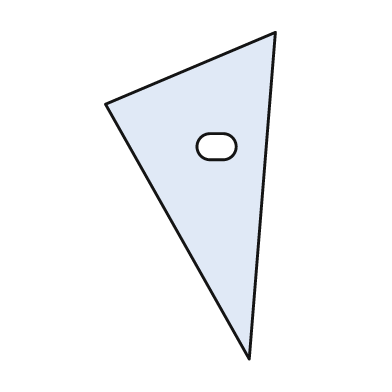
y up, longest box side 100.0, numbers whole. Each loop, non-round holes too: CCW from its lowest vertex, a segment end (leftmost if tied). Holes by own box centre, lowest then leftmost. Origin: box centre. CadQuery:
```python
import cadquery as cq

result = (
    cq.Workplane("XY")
    .moveTo(18.0, -50.0)
    .lineTo(26.0, 50.0)
    .lineTo(-26.0, 28.0)
    .close()
    .moveTo(6.0, 11.0)
    .lineTo(10.0, 11.0)
    .threePointArc((14.0, 15.0), (10.0, 19.0))
    .lineTo(6.0, 19.0)
    .threePointArc((2.0, 15.0), (6.0, 11.0))
    .close()
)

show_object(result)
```